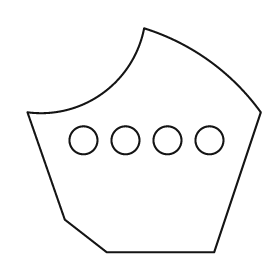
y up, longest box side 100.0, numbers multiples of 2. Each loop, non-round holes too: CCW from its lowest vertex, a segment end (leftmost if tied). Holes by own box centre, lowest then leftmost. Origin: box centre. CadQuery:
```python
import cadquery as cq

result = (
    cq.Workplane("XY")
    .moveTo(-16.0, -48.0)
    .lineTo(30.0, -48.0)
    .lineTo(50.0, 12.0)
    .threePointArc((28.0, 34.0), (0.0, 48.0))
    .threePointArc((-18.0, 20.0), (-50.0, 12.0))
    .lineTo(-34.0, -34.0)
    .close()
    .moveTo(-26.0, 0.0)
    .circle(6.0)
    .moveTo(-8.0, 0.0)
    .circle(6.0)
    .moveTo(10.0, 0.0)
    .circle(6.0)
    .moveTo(28.0, 0.0)
    .circle(6.0)
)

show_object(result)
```